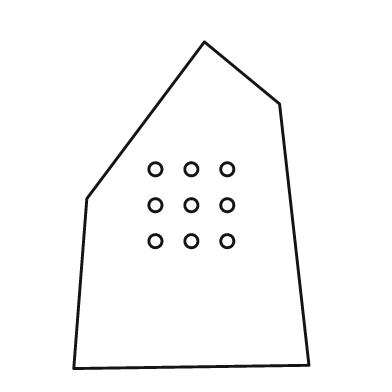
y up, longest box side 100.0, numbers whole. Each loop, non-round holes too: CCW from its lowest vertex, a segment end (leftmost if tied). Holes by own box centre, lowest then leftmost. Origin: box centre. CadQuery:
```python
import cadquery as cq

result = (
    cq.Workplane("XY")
    .moveTo(-36.0, -50.0)
    .lineTo(36.0, -49.0)
    .lineTo(27.0, 31.0)
    .lineTo(4.0, 50.0)
    .lineTo(-32.0, 2.0)
    .close()
    .moveTo(-11.0, -11.0)
    .circle(2.0)
    .moveTo(0.0, -11.0)
    .circle(2.0)
    .moveTo(11.0, -11.0)
    .circle(2.0)
    .moveTo(-11.0, 0.0)
    .circle(2.0)
    .moveTo(0.0, 0.0)
    .circle(2.0)
    .moveTo(11.0, 0.0)
    .circle(2.0)
    .moveTo(-11.0, 11.0)
    .circle(2.0)
    .moveTo(0.0, 11.0)
    .circle(2.0)
    .moveTo(11.0, 11.0)
    .circle(2.0)
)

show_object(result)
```